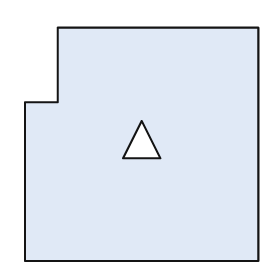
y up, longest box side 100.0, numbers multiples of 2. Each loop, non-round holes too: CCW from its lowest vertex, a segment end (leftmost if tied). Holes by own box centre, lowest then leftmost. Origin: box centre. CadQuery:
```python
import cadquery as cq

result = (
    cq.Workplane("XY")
    .moveTo(-50.0, -50.0)
    .lineTo(50.0, -50.0)
    .lineTo(50.0, 50.0)
    .lineTo(-36.0, 50.0)
    .lineTo(-36.0, 18.0)
    .lineTo(-50.0, 18.0)
    .close()
    .moveTo(-8.0, -6.0)
    .lineTo(8.0, -6.0)
    .lineTo(0.0, 10.0)
    .close()
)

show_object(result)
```